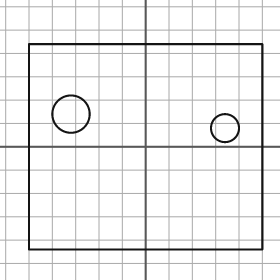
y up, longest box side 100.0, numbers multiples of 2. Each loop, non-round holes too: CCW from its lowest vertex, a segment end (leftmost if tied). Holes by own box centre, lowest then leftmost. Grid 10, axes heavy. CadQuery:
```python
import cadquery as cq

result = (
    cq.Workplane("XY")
    .moveTo(-50.0, -44.0)
    .lineTo(50.0, -44.0)
    .lineTo(50.0, 44.0)
    .lineTo(-50.0, 44.0)
    .close()
    .moveTo(34.0, 8.0)
    .circle(6.0)
    .moveTo(-32.0, 14.0)
    .circle(8.0)
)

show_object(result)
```